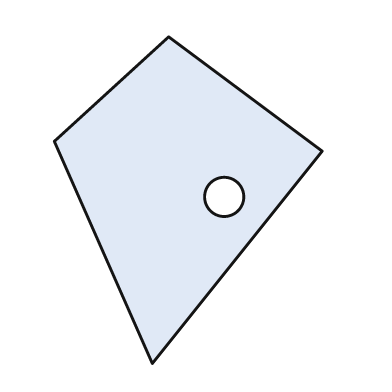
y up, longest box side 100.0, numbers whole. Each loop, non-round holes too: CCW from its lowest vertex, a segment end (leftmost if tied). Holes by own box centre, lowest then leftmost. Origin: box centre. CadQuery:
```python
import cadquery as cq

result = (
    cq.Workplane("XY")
    .moveTo(-11.0, -50.0)
    .lineTo(41.0, 15.0)
    .lineTo(-6.0, 50.0)
    .lineTo(-41.0, 18.0)
    .close()
    .moveTo(11.0, 1.0)
    .circle(6.0)
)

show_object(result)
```